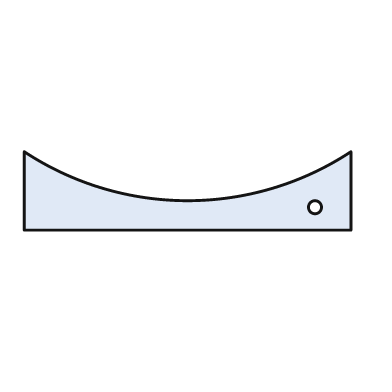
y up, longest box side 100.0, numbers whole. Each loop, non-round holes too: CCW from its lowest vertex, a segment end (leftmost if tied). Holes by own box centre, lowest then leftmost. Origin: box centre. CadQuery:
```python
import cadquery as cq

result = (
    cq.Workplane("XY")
    .moveTo(-50.0, -12.0)
    .lineTo(50.0, -12.0)
    .lineTo(50.0, 12.0)
    .threePointArc((0.0, -3.0), (-50.0, 12.0))
    .close()
    .moveTo(39.0, -5.0)
    .circle(2.0)
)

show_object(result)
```